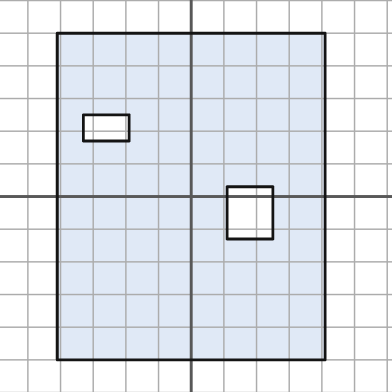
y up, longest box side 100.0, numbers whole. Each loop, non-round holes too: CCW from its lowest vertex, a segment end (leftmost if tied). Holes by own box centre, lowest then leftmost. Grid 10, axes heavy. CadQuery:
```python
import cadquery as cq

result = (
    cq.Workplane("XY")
    .moveTo(-41.0, -50.0)
    .lineTo(41.0, -50.0)
    .lineTo(41.0, 50.0)
    .lineTo(-41.0, 50.0)
    .close()
    .moveTo(11.0, -13.0)
    .lineTo(25.0, -13.0)
    .lineTo(25.0, 3.0)
    .lineTo(11.0, 3.0)
    .close()
    .moveTo(-33.0, 17.0)
    .lineTo(-19.0, 17.0)
    .lineTo(-19.0, 25.0)
    .lineTo(-33.0, 25.0)
    .close()
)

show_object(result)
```